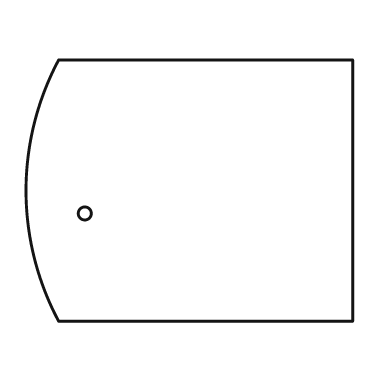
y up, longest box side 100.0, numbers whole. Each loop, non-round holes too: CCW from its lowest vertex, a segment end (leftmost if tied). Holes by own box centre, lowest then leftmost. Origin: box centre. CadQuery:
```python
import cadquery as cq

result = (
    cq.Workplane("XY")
    .moveTo(-40.0, -40.0)
    .lineTo(50.0, -40.0)
    .lineTo(50.0, 40.0)
    .lineTo(-40.0, 40.0)
    .threePointArc((-50.0, 0.0), (-40.0, -40.0))
    .close()
    .moveTo(-32.0, -7.0)
    .circle(2.0)
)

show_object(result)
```